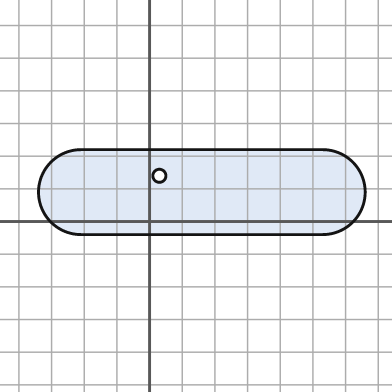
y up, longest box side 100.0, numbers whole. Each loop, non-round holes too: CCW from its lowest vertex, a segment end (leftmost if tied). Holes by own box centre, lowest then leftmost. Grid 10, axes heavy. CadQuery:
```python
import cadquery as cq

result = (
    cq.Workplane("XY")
    .moveTo(-21.0, -4.0)
    .lineTo(53.0, -4.0)
    .threePointArc((66.0, 9.0), (53.0, 22.0))
    .lineTo(-21.0, 22.0)
    .threePointArc((-34.0, 9.0), (-21.0, -4.0))
    .close()
    .moveTo(3.0, 14.0)
    .circle(2.0)
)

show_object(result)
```